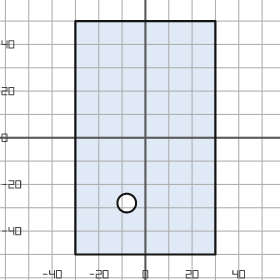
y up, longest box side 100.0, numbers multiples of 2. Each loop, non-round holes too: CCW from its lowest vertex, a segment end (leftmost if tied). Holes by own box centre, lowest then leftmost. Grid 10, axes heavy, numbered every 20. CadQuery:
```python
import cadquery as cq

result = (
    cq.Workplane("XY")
    .moveTo(-30.0, -50.0)
    .lineTo(30.0, -50.0)
    .lineTo(30.0, 50.0)
    .lineTo(-30.0, 50.0)
    .close()
    .moveTo(-8.0, -28.0)
    .circle(4.0)
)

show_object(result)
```